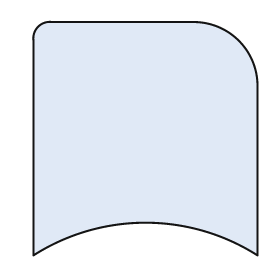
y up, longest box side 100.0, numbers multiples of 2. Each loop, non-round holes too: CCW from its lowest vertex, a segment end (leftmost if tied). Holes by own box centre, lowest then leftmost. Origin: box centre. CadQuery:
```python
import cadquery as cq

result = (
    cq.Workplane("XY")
    .moveTo(-48.0, -50.0)
    .threePointArc((0.0, -36.0), (48.0, -50.0))
    .lineTo(48.0, 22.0)
    .threePointArc((40.0, 42.0), (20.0, 50.0))
    .lineTo(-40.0, 50.0)
    .threePointArc((-46.0, 48.0), (-48.0, 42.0))
    .close()
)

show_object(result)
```